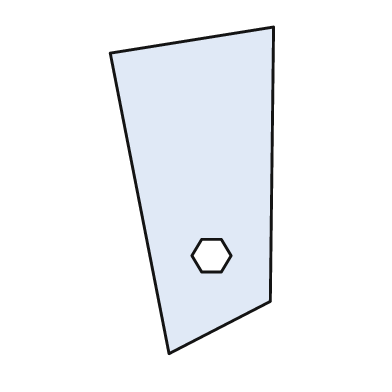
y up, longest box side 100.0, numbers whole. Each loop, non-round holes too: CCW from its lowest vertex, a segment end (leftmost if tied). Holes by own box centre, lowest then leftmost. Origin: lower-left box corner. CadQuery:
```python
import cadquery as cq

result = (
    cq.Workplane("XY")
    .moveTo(18.0, 0.0)
    .lineTo(49.0, 16.0)
    .lineTo(50.0, 100.0)
    .lineTo(0.0, 92.0)
    .close()
    .moveTo(28.0, 25.0)
    .lineTo(34.0, 25.0)
    .lineTo(37.0, 30.0)
    .lineTo(34.0, 35.0)
    .lineTo(28.0, 35.0)
    .lineTo(25.0, 30.0)
    .close()
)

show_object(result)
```